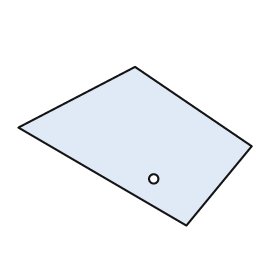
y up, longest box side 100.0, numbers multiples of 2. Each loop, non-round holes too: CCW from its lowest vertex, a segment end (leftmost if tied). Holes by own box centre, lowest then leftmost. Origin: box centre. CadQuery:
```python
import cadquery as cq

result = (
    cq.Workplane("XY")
    .moveTo(22.0, -34.0)
    .lineTo(50.0, 0.0)
    .lineTo(0.0, 34.0)
    .lineTo(-50.0, 8.0)
    .close()
    .moveTo(8.0, -14.0)
    .circle(2.0)
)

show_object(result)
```